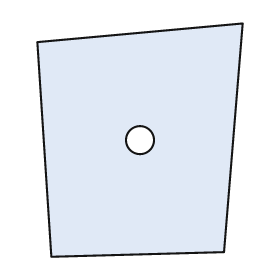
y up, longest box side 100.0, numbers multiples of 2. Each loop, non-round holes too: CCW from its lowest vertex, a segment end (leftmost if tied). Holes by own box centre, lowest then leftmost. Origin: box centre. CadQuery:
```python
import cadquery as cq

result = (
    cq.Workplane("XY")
    .moveTo(-38.0, -50.0)
    .lineTo(36.0, -48.0)
    .lineTo(44.0, 50.0)
    .lineTo(-44.0, 42.0)
    .close()
    .moveTo(0.0, 0.0)
    .circle(6.0)
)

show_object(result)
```